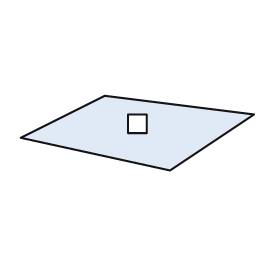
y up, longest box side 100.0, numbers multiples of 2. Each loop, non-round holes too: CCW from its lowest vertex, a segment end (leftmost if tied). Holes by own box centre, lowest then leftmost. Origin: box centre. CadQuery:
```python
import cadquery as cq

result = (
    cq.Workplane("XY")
    .moveTo(14.0, -16.0)
    .lineTo(50.0, 8.0)
    .lineTo(-14.0, 16.0)
    .lineTo(-50.0, -2.0)
    .close()
    .moveTo(-4.0, 0.0)
    .lineTo(4.0, 0.0)
    .lineTo(4.0, 8.0)
    .lineTo(-4.0, 8.0)
    .close()
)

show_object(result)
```